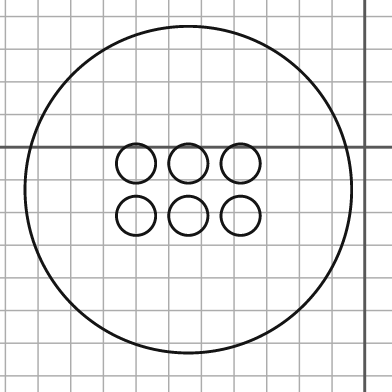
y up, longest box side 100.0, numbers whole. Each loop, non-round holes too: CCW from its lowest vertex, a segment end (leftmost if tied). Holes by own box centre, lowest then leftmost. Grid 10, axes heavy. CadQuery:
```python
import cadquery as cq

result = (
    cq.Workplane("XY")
    .moveTo(-54.0, -13.0)
    .circle(50.0)
    .moveTo(-70.0, -21.0)
    .circle(6.0)
    .moveTo(-54.0, -21.0)
    .circle(6.0)
    .moveTo(-38.0, -21.0)
    .circle(6.0)
    .moveTo(-70.0, -5.0)
    .circle(6.0)
    .moveTo(-54.0, -5.0)
    .circle(6.0)
    .moveTo(-38.0, -5.0)
    .circle(6.0)
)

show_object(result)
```